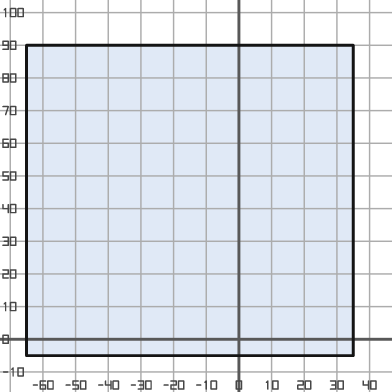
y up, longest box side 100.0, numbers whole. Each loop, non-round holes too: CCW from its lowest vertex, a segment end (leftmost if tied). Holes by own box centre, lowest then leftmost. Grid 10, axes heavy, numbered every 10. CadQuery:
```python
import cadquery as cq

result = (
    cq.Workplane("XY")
    .moveTo(-65.0, -5.0)
    .lineTo(35.0, -5.0)
    .lineTo(35.0, 90.0)
    .lineTo(-65.0, 90.0)
    .close()
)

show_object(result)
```